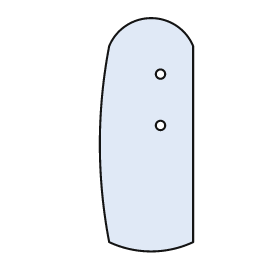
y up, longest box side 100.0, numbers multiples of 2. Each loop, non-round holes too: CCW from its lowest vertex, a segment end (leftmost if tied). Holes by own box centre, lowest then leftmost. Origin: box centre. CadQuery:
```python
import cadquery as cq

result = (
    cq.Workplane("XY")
    .moveTo(-16.0, -46.0)
    .threePointArc((2.0, -50.0), (20.0, -46.0))
    .lineTo(20.0, 38.0)
    .threePointArc((2.0, 50.0), (-16.0, 38.0))
    .threePointArc((-20.0, -4.0), (-16.0, -46.0))
    .close()
    .moveTo(6.0, 4.0)
    .circle(2.0)
    .moveTo(6.0, 26.0)
    .circle(2.0)
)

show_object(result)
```